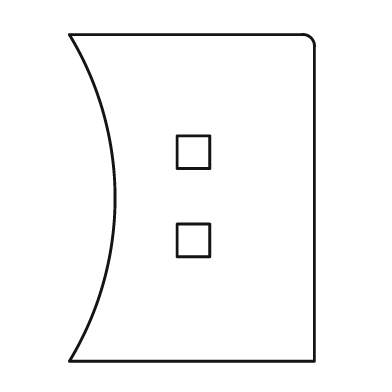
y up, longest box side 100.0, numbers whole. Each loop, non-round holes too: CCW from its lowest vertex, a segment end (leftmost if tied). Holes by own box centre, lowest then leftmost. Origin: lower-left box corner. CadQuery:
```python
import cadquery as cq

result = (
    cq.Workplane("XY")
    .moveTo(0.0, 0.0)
    .lineTo(75.0, 0.0)
    .lineTo(75.0, 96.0)
    .threePointArc((74.0, 99.0), (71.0, 100.0))
    .lineTo(0.0, 100.0)
    .threePointArc((14.0, 50.0), (0.0, 0.0))
    .close()
    .moveTo(33.0, 32.0)
    .lineTo(43.0, 32.0)
    .lineTo(43.0, 42.0)
    .lineTo(33.0, 42.0)
    .close()
    .moveTo(33.0, 59.0)
    .lineTo(43.0, 59.0)
    .lineTo(43.0, 69.0)
    .lineTo(33.0, 69.0)
    .close()
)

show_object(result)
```